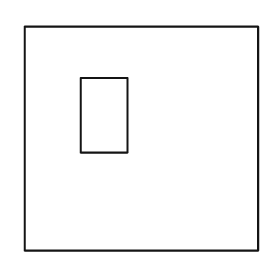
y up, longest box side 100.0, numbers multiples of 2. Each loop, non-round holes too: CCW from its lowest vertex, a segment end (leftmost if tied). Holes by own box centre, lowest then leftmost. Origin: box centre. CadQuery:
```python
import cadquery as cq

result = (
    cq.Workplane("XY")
    .moveTo(-50.0, -48.0)
    .lineTo(50.0, -48.0)
    .lineTo(50.0, 48.0)
    .lineTo(-50.0, 48.0)
    .close()
    .moveTo(-26.0, -6.0)
    .lineTo(-6.0, -6.0)
    .lineTo(-6.0, 26.0)
    .lineTo(-26.0, 26.0)
    .close()
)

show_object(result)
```